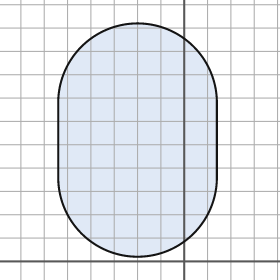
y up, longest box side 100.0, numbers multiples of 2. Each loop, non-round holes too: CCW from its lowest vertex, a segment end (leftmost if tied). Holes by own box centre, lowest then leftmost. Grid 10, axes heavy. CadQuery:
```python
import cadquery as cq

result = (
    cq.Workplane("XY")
    .moveTo(-54.0, 36.0)
    .threePointArc((-20.0, 2.0), (14.0, 36.0))
    .lineTo(14.0, 68.0)
    .threePointArc((-20.0, 102.0), (-54.0, 68.0))
    .close()
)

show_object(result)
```